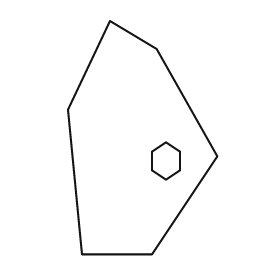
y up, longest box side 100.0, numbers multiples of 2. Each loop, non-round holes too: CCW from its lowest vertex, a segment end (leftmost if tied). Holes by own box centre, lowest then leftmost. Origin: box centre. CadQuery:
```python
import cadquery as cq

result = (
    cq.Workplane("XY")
    .moveTo(-26.0, -50.0)
    .lineTo(4.0, -50.0)
    .lineTo(32.0, -8.0)
    .lineTo(6.0, 38.0)
    .lineTo(-14.0, 50.0)
    .lineTo(-32.0, 12.0)
    .close()
    .moveTo(10.0, -18.0)
    .lineTo(16.0, -14.0)
    .lineTo(16.0, -6.0)
    .lineTo(10.0, -2.0)
    .lineTo(4.0, -6.0)
    .lineTo(4.0, -14.0)
    .close()
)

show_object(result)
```